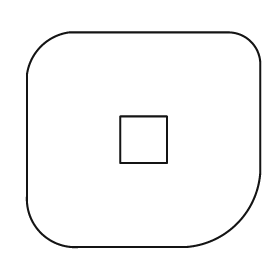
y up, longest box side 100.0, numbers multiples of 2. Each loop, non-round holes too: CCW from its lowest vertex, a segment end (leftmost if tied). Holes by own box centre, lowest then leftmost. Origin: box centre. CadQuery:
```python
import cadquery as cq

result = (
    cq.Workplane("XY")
    .moveTo(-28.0, -46.0)
    .lineTo(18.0, -46.0)
    .threePointArc((40.0, -36.0), (50.0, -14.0))
    .lineTo(50.0, 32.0)
    .threePointArc((46.0, 42.0), (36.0, 46.0))
    .lineTo(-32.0, 46.0)
    .threePointArc((-44.0, 40.0), (-50.0, 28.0))
    .lineTo(-50.0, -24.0)
    .threePointArc((-44.0, -40.0), (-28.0, -46.0))
    .close()
    .moveTo(-10.0, -10.0)
    .lineTo(10.0, -10.0)
    .lineTo(10.0, 10.0)
    .lineTo(-10.0, 10.0)
    .close()
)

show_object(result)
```